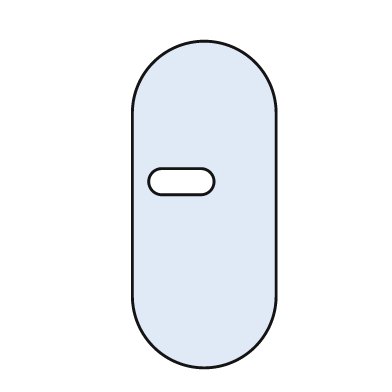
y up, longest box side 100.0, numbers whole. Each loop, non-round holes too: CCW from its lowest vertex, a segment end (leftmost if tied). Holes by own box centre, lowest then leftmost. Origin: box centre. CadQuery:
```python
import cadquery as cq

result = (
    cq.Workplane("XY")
    .moveTo(-22.0, -28.0)
    .threePointArc((0.0, -50.0), (22.0, -28.0))
    .lineTo(22.0, 28.0)
    .threePointArc((0.0, 50.0), (-22.0, 28.0))
    .close()
    .moveTo(-13.0, 3.0)
    .lineTo(-1.0, 3.0)
    .threePointArc((3.0, 7.0), (-1.0, 11.0))
    .lineTo(-13.0, 11.0)
    .threePointArc((-17.0, 7.0), (-13.0, 3.0))
    .close()
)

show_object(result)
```